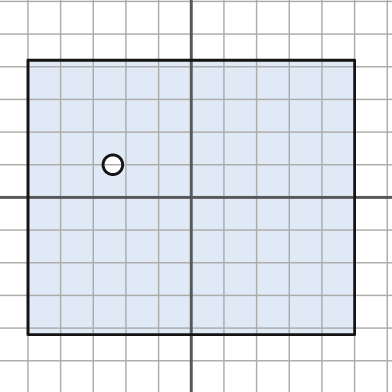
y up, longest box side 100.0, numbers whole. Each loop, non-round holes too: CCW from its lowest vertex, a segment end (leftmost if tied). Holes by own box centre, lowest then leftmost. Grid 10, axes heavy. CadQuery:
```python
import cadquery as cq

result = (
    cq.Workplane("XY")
    .moveTo(-50.0, -42.0)
    .lineTo(50.0, -42.0)
    .lineTo(50.0, 42.0)
    .lineTo(-50.0, 42.0)
    .close()
    .moveTo(-24.0, 10.0)
    .circle(3.0)
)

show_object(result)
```